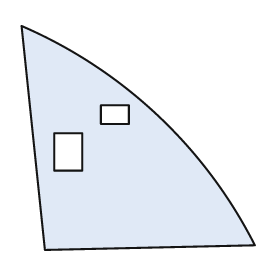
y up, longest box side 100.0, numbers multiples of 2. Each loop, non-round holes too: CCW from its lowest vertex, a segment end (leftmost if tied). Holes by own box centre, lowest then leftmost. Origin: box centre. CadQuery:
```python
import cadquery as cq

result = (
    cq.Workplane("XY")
    .moveTo(-40.0, -48.0)
    .lineTo(50.0, -46.0)
    .threePointArc((8.0, 10.0), (-50.0, 48.0))
    .close()
    .moveTo(-36.0, -14.0)
    .lineTo(-24.0, -14.0)
    .lineTo(-24.0, 2.0)
    .lineTo(-36.0, 2.0)
    .close()
    .moveTo(-16.0, 6.0)
    .lineTo(-4.0, 6.0)
    .lineTo(-4.0, 14.0)
    .lineTo(-16.0, 14.0)
    .close()
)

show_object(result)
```